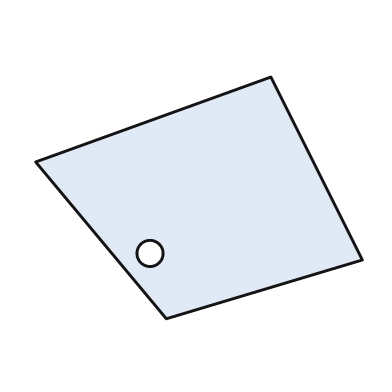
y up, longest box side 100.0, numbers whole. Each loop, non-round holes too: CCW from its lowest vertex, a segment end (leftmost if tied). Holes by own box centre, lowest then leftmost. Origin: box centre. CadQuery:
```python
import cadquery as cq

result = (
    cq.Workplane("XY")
    .moveTo(-10.0, -37.0)
    .lineTo(50.0, -19.0)
    .lineTo(22.0, 37.0)
    .lineTo(-50.0, 11.0)
    .close()
    .moveTo(-15.0, -17.0)
    .circle(4.0)
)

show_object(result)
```